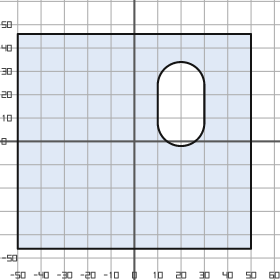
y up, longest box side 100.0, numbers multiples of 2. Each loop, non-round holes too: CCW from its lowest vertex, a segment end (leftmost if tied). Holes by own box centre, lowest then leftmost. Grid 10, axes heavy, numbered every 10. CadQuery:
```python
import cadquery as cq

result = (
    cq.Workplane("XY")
    .moveTo(-50.0, -46.0)
    .lineTo(50.0, -46.0)
    .lineTo(50.0, 46.0)
    .lineTo(-50.0, 46.0)
    .close()
    .moveTo(10.0, 8.0)
    .threePointArc((20.0, -2.0), (30.0, 8.0))
    .lineTo(30.0, 24.0)
    .threePointArc((20.0, 34.0), (10.0, 24.0))
    .close()
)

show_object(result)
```